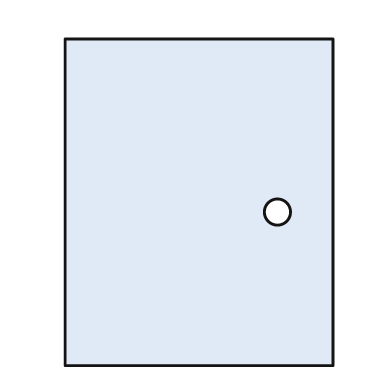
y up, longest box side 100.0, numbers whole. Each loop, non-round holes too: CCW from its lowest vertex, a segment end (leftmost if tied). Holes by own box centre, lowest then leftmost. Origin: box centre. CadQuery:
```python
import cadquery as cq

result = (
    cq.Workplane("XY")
    .moveTo(-41.0, -50.0)
    .lineTo(41.0, -50.0)
    .lineTo(41.0, 50.0)
    .lineTo(-41.0, 50.0)
    .close()
    .moveTo(24.0, -3.0)
    .circle(4.0)
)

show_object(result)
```